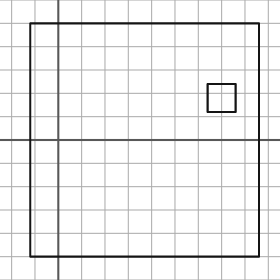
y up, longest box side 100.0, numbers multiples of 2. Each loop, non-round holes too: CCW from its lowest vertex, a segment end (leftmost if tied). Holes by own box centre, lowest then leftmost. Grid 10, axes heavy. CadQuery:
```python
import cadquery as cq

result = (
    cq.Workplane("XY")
    .moveTo(-12.0, -50.0)
    .lineTo(86.0, -50.0)
    .lineTo(86.0, 50.0)
    .lineTo(-12.0, 50.0)
    .close()
    .moveTo(64.0, 12.0)
    .lineTo(76.0, 12.0)
    .lineTo(76.0, 24.0)
    .lineTo(64.0, 24.0)
    .close()
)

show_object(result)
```